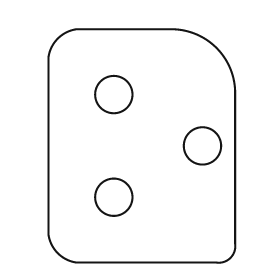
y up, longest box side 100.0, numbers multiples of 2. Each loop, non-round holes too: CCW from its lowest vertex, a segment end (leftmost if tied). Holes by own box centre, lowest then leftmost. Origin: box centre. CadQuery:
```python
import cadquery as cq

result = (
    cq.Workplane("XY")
    .moveTo(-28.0, -50.0)
    .lineTo(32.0, -50.0)
    .threePointArc((38.0, -48.0), (40.0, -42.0))
    .lineTo(40.0, 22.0)
    .threePointArc((32.0, 42.0), (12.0, 50.0))
    .lineTo(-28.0, 50.0)
    .threePointArc((-36.0, 46.0), (-40.0, 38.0))
    .lineTo(-40.0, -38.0)
    .threePointArc((-36.0, -46.0), (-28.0, -50.0))
    .close()
    .moveTo(-12.0, -22.0)
    .circle(8.0)
    .moveTo(26.0, 0.0)
    .circle(8.0)
    .moveTo(-12.0, 22.0)
    .circle(8.0)
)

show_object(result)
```